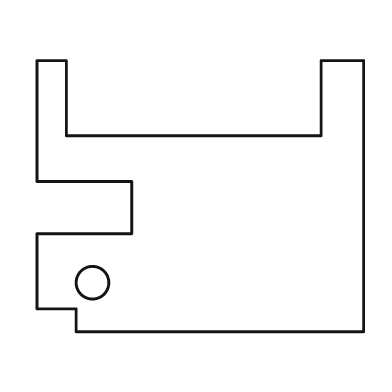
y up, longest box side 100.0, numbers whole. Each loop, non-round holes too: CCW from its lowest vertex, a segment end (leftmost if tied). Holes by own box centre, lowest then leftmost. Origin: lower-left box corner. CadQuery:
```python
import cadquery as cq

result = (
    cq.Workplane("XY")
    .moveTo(12.0, 0.0)
    .lineTo(100.0, 0.0)
    .lineTo(100.0, 83.0)
    .lineTo(87.0, 83.0)
    .lineTo(87.0, 60.0)
    .lineTo(9.0, 60.0)
    .lineTo(9.0, 83.0)
    .lineTo(0.0, 83.0)
    .lineTo(0.0, 46.0)
    .lineTo(29.0, 46.0)
    .lineTo(29.0, 30.0)
    .lineTo(0.0, 30.0)
    .lineTo(0.0, 7.0)
    .lineTo(12.0, 7.0)
    .close()
    .moveTo(17.0, 15.0)
    .circle(5.0)
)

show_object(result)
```